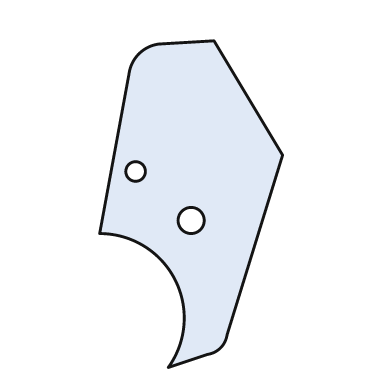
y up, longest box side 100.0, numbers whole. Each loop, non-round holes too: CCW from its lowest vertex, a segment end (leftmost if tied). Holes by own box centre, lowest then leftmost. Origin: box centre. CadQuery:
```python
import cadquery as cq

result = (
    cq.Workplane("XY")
    .moveTo(-7.0, -50.0)
    .lineTo(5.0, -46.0)
    .threePointArc((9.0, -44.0), (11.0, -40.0))
    .lineTo(28.0, 15.0)
    .lineTo(7.0, 50.0)
    .lineTo(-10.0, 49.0)
    .threePointArc((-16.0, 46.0), (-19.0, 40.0))
    .lineTo(-28.0, -9.0)
    .threePointArc((-5.0, -23.0), (-7.0, -50.0))
    .close()
    .moveTo(0.0, -5.0)
    .circle(4.0)
    .moveTo(-17.0, 10.0)
    .circle(3.0)
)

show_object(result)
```